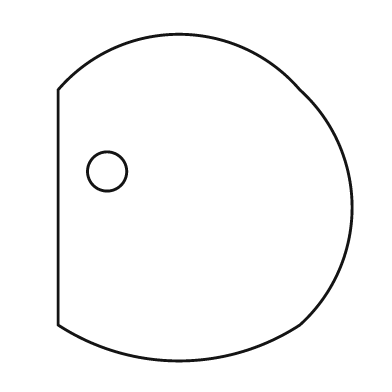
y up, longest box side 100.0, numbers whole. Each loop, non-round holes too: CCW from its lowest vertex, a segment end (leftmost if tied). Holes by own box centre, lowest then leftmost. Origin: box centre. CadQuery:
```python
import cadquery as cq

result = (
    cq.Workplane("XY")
    .moveTo(-45.0, -39.0)
    .threePointArc((-8.0, -50.0), (29.0, -39.0))
    .threePointArc((45.0, -3.0), (29.0, 33.0))
    .threePointArc((-8.0, 50.0), (-45.0, 33.0))
    .close()
    .moveTo(-30.0, 8.0)
    .circle(6.0)
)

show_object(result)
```